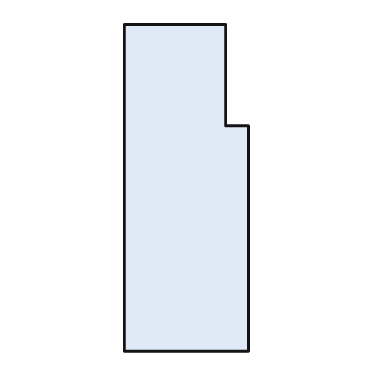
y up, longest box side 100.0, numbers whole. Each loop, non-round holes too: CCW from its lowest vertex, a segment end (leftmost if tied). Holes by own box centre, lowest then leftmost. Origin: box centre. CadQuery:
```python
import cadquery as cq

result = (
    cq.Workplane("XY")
    .moveTo(-19.0, -50.0)
    .lineTo(19.0, -50.0)
    .lineTo(19.0, 19.0)
    .lineTo(12.0, 19.0)
    .lineTo(12.0, 50.0)
    .lineTo(-19.0, 50.0)
    .close()
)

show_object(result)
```